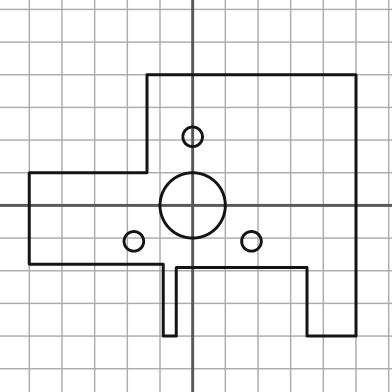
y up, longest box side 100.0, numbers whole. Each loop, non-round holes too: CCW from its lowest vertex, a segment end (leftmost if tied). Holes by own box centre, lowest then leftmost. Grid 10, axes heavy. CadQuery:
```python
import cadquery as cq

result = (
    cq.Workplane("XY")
    .moveTo(-9.0, -40.0)
    .lineTo(-5.0, -40.0)
    .lineTo(-5.0, -19.0)
    .lineTo(35.0, -19.0)
    .lineTo(35.0, -40.0)
    .lineTo(50.0, -40.0)
    .lineTo(50.0, 40.0)
    .lineTo(-14.0, 40.0)
    .lineTo(-14.0, 10.0)
    .lineTo(-50.0, 10.0)
    .lineTo(-50.0, -18.0)
    .lineTo(-9.0, -18.0)
    .close()
    .moveTo(-18.0, -11.0)
    .circle(3.0)
    .moveTo(18.0, -11.0)
    .circle(3.0)
    .moveTo(0.0, 0.0)
    .circle(10.0)
    .moveTo(0.0, 21.0)
    .circle(3.0)
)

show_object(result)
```